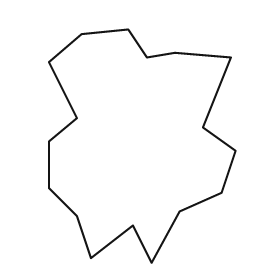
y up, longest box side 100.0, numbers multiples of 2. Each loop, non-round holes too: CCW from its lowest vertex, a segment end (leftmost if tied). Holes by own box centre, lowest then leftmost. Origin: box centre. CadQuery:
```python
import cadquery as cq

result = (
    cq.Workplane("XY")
    .moveTo(4.0, -50.0)
    .lineTo(16.0, -28.0)
    .lineTo(34.0, -20.0)
    .lineTo(40.0, -2.0)
    .lineTo(26.0, 8.0)
    .lineTo(38.0, 38.0)
    .lineTo(14.0, 40.0)
    .lineTo(2.0, 38.0)
    .lineTo(-6.0, 50.0)
    .lineTo(-26.0, 48.0)
    .lineTo(-40.0, 36.0)
    .lineTo(-28.0, 12.0)
    .lineTo(-40.0, 2.0)
    .lineTo(-40.0, -18.0)
    .lineTo(-28.0, -30.0)
    .lineTo(-22.0, -48.0)
    .lineTo(-4.0, -34.0)
    .close()
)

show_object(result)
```